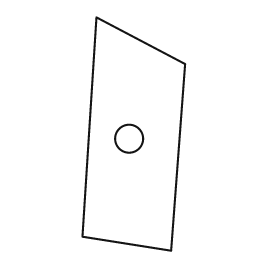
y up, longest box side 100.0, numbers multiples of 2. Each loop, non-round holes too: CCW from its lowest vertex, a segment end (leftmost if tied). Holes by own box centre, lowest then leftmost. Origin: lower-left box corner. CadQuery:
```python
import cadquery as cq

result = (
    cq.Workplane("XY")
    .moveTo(38.0, 0.0)
    .lineTo(44.0, 80.0)
    .lineTo(6.0, 100.0)
    .lineTo(0.0, 6.0)
    .close()
    .moveTo(20.0, 48.0)
    .circle(6.0)
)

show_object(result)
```